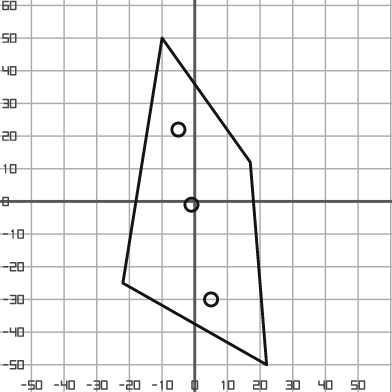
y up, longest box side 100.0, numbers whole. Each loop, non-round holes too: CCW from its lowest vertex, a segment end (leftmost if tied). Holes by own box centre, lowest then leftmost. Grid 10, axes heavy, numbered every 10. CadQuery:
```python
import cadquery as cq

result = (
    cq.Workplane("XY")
    .moveTo(22.0, -50.0)
    .lineTo(17.0, 12.0)
    .lineTo(-10.0, 50.0)
    .lineTo(-22.0, -25.0)
    .close()
    .moveTo(5.0, -30.0)
    .circle(2.0)
    .moveTo(-1.0, -1.0)
    .circle(2.0)
    .moveTo(-5.0, 22.0)
    .circle(2.0)
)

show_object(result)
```